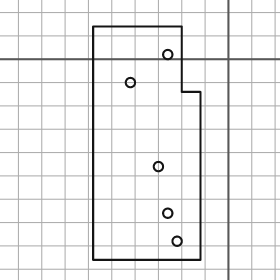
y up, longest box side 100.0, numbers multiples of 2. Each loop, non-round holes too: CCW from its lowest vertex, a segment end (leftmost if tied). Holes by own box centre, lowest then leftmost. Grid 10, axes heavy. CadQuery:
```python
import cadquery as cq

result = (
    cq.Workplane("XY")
    .moveTo(-58.0, -86.0)
    .lineTo(-12.0, -86.0)
    .lineTo(-12.0, -14.0)
    .lineTo(-20.0, -14.0)
    .lineTo(-20.0, 14.0)
    .lineTo(-58.0, 14.0)
    .close()
    .moveTo(-22.0, -78.0)
    .circle(2.0)
    .moveTo(-26.0, -66.0)
    .circle(2.0)
    .moveTo(-30.0, -46.0)
    .circle(2.0)
    .moveTo(-42.0, -10.0)
    .circle(2.0)
    .moveTo(-26.0, 2.0)
    .circle(2.0)
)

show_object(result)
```